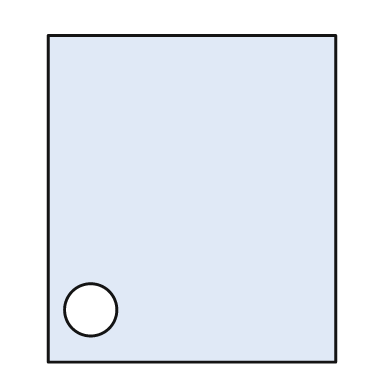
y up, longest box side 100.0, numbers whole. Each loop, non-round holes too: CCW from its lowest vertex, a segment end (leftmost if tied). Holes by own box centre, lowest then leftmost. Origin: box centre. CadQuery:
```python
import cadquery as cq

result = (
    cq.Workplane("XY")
    .moveTo(-44.0, -50.0)
    .lineTo(44.0, -50.0)
    .lineTo(44.0, 50.0)
    .lineTo(-44.0, 50.0)
    .close()
    .moveTo(-31.0, -34.0)
    .circle(8.0)
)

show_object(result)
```